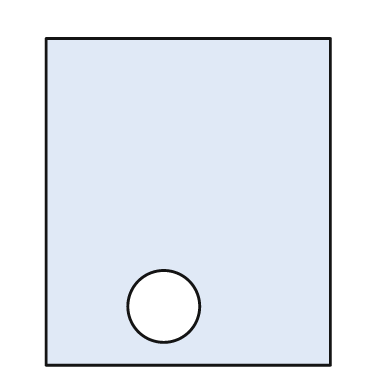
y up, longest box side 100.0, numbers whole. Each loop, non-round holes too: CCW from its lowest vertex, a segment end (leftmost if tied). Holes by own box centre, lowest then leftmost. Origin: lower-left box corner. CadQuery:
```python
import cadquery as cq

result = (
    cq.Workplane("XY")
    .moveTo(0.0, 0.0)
    .lineTo(87.0, 0.0)
    .lineTo(87.0, 100.0)
    .lineTo(0.0, 100.0)
    .close()
    .moveTo(36.0, 18.0)
    .circle(11.0)
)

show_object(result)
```